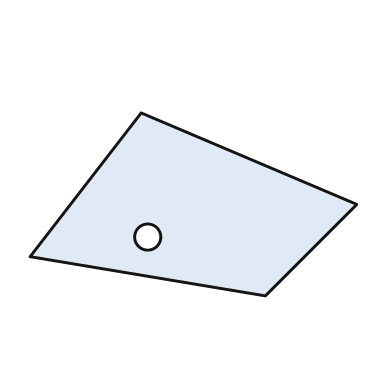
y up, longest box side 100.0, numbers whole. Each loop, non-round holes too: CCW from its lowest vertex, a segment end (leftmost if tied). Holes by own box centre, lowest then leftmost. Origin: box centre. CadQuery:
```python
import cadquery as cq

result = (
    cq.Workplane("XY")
    .moveTo(22.0, -28.0)
    .lineTo(50.0, 0.0)
    .lineTo(-16.0, 28.0)
    .lineTo(-50.0, -16.0)
    .close()
    .moveTo(-14.0, -10.0)
    .circle(4.0)
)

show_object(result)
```